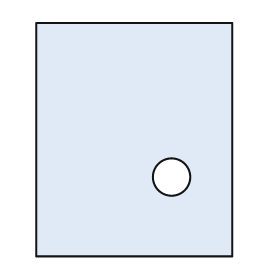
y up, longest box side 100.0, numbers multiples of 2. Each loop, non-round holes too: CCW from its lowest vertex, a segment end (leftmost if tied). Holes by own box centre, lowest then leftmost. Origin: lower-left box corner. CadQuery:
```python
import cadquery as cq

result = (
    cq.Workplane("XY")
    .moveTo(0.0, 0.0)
    .lineTo(84.0, 0.0)
    .lineTo(84.0, 100.0)
    .lineTo(0.0, 100.0)
    .close()
    .moveTo(58.0, 34.0)
    .circle(8.0)
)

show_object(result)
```